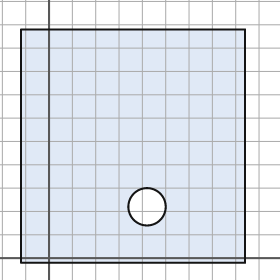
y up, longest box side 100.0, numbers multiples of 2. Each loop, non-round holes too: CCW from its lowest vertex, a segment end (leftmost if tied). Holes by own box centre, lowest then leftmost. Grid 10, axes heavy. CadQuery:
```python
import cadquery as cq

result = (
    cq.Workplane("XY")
    .moveTo(-12.0, -2.0)
    .lineTo(84.0, -2.0)
    .lineTo(84.0, 98.0)
    .lineTo(-12.0, 98.0)
    .close()
    .moveTo(42.0, 22.0)
    .circle(8.0)
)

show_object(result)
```